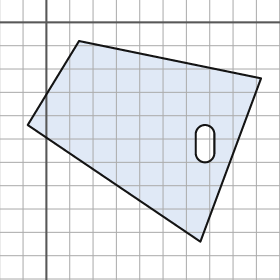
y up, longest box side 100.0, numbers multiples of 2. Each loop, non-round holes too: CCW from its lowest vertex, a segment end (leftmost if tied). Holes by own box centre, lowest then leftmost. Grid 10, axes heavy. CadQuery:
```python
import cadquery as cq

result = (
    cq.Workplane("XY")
    .moveTo(66.0, -94.0)
    .lineTo(92.0, -24.0)
    .lineTo(14.0, -8.0)
    .lineTo(-8.0, -44.0)
    .close()
    .moveTo(64.0, -56.0)
    .threePointArc((68.0, -60.0), (72.0, -56.0))
    .lineTo(72.0, -48.0)
    .threePointArc((68.0, -44.0), (64.0, -48.0))
    .close()
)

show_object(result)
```